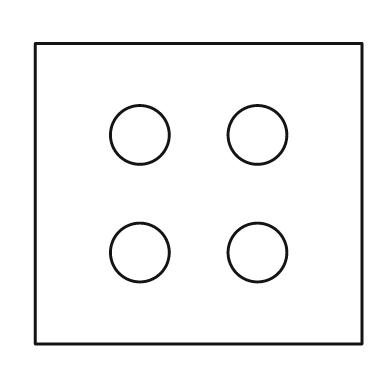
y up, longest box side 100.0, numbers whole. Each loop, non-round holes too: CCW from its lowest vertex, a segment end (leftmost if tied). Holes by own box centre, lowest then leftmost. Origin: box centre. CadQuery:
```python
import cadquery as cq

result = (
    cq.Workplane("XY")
    .moveTo(-50.0, -46.0)
    .lineTo(50.0, -46.0)
    .lineTo(50.0, 46.0)
    .lineTo(-50.0, 46.0)
    .close()
    .moveTo(-18.0, -18.0)
    .circle(9.0)
    .moveTo(18.0, -18.0)
    .circle(9.0)
    .moveTo(-18.0, 18.0)
    .circle(9.0)
    .moveTo(18.0, 18.0)
    .circle(9.0)
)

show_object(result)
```